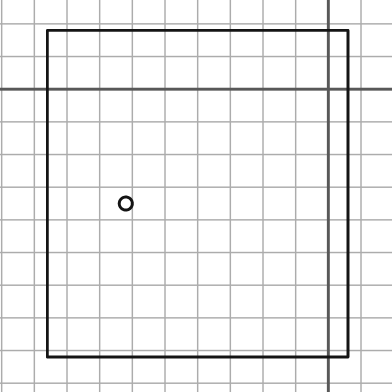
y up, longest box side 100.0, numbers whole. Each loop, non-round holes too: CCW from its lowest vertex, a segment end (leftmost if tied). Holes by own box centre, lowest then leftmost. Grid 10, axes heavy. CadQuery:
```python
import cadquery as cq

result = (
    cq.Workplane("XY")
    .moveTo(-86.0, -82.0)
    .lineTo(6.0, -82.0)
    .lineTo(6.0, 18.0)
    .lineTo(-86.0, 18.0)
    .close()
    .moveTo(-62.0, -35.0)
    .circle(2.0)
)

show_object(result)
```